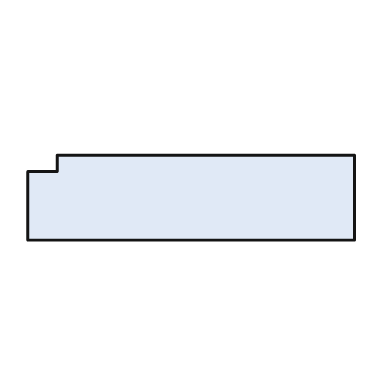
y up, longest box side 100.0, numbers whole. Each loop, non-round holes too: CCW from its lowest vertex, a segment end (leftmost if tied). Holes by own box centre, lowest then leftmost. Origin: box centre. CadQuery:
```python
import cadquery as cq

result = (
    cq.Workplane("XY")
    .moveTo(-50.0, -13.0)
    .lineTo(50.0, -13.0)
    .lineTo(50.0, 13.0)
    .lineTo(-41.0, 13.0)
    .lineTo(-41.0, 8.0)
    .lineTo(-50.0, 8.0)
    .close()
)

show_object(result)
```